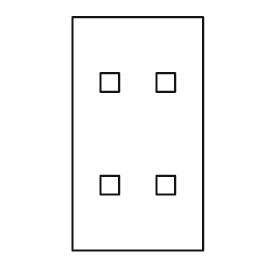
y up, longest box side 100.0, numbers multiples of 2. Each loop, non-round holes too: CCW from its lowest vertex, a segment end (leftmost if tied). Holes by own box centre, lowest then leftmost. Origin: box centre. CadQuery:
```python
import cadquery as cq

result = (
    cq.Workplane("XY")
    .moveTo(-28.0, -50.0)
    .lineTo(28.0, -50.0)
    .lineTo(28.0, 50.0)
    .lineTo(-28.0, 50.0)
    .close()
    .moveTo(-16.0, -26.0)
    .lineTo(-8.0, -26.0)
    .lineTo(-8.0, -18.0)
    .lineTo(-16.0, -18.0)
    .close()
    .moveTo(8.0, -26.0)
    .lineTo(16.0, -26.0)
    .lineTo(16.0, -18.0)
    .lineTo(8.0, -18.0)
    .close()
    .moveTo(-16.0, 18.0)
    .lineTo(-8.0, 18.0)
    .lineTo(-8.0, 26.0)
    .lineTo(-16.0, 26.0)
    .close()
    .moveTo(8.0, 18.0)
    .lineTo(16.0, 18.0)
    .lineTo(16.0, 26.0)
    .lineTo(8.0, 26.0)
    .close()
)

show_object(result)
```